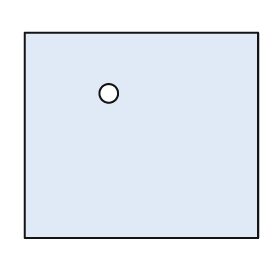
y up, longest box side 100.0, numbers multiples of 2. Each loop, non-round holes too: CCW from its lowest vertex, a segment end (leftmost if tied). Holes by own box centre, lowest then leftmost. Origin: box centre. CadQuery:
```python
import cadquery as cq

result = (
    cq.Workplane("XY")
    .moveTo(-50.0, -44.0)
    .lineTo(50.0, -44.0)
    .lineTo(50.0, 44.0)
    .lineTo(-50.0, 44.0)
    .close()
    .moveTo(-14.0, 18.0)
    .circle(4.0)
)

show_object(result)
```